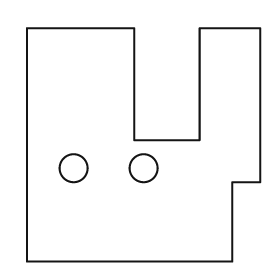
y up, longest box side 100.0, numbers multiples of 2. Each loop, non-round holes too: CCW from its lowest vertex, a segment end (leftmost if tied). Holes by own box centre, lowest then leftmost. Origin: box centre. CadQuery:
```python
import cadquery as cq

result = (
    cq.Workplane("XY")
    .moveTo(-50.0, -50.0)
    .lineTo(38.0, -50.0)
    .lineTo(38.0, -16.0)
    .lineTo(50.0, -16.0)
    .lineTo(50.0, 50.0)
    .lineTo(24.0, 50.0)
    .lineTo(24.0, 2.0)
    .lineTo(-4.0, 2.0)
    .lineTo(-4.0, 50.0)
    .lineTo(-50.0, 50.0)
    .close()
    .moveTo(-30.0, -10.0)
    .circle(6.0)
    .moveTo(0.0, -10.0)
    .circle(6.0)
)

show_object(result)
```